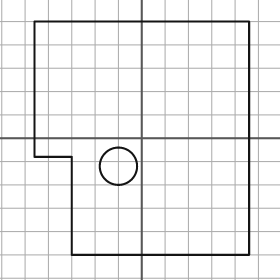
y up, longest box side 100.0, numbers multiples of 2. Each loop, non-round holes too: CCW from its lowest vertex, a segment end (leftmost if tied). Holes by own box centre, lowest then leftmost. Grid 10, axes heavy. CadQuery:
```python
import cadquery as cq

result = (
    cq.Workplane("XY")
    .moveTo(-30.0, -50.0)
    .lineTo(46.0, -50.0)
    .lineTo(46.0, 50.0)
    .lineTo(-46.0, 50.0)
    .lineTo(-46.0, -8.0)
    .lineTo(-30.0, -8.0)
    .close()
    .moveTo(-10.0, -12.0)
    .circle(8.0)
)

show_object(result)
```